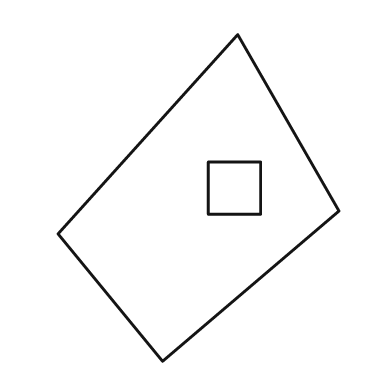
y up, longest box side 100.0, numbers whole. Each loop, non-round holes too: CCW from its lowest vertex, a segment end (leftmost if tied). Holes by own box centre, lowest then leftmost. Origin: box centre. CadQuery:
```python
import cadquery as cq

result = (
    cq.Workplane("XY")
    .moveTo(-11.0, -50.0)
    .lineTo(43.0, -4.0)
    .lineTo(12.0, 50.0)
    .lineTo(-43.0, -11.0)
    .close()
    .moveTo(3.0, -5.0)
    .lineTo(19.0, -5.0)
    .lineTo(19.0, 11.0)
    .lineTo(3.0, 11.0)
    .close()
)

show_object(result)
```